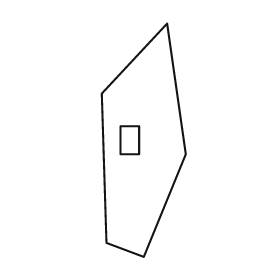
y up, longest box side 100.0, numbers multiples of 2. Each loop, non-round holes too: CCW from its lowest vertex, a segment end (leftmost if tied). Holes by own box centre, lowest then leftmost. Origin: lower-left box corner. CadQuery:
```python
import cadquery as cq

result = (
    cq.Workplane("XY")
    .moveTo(18.0, 0.0)
    .lineTo(36.0, 44.0)
    .lineTo(28.0, 100.0)
    .lineTo(0.0, 70.0)
    .lineTo(2.0, 6.0)
    .close()
    .moveTo(8.0, 44.0)
    .lineTo(16.0, 44.0)
    .lineTo(16.0, 56.0)
    .lineTo(8.0, 56.0)
    .close()
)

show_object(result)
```